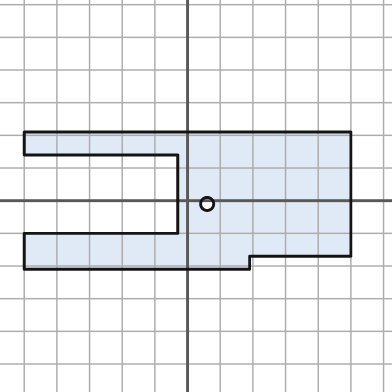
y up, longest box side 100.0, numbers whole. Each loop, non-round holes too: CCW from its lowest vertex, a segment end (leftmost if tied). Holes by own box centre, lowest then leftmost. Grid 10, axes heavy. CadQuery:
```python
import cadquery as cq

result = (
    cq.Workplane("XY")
    .moveTo(-50.0, -21.0)
    .lineTo(19.0, -21.0)
    .lineTo(19.0, -17.0)
    .lineTo(50.0, -17.0)
    .lineTo(50.0, 21.0)
    .lineTo(-50.0, 21.0)
    .lineTo(-50.0, 14.0)
    .lineTo(-3.0, 14.0)
    .lineTo(-3.0, -10.0)
    .lineTo(-50.0, -10.0)
    .close()
    .moveTo(6.0, -1.0)
    .circle(2.0)
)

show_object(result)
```